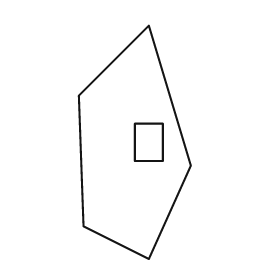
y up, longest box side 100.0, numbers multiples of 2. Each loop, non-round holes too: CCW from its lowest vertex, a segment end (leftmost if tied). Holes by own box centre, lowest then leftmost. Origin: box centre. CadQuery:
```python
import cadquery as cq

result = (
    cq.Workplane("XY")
    .moveTo(6.0, -50.0)
    .lineTo(24.0, -10.0)
    .lineTo(6.0, 50.0)
    .lineTo(-24.0, 20.0)
    .lineTo(-22.0, -36.0)
    .close()
    .moveTo(0.0, -8.0)
    .lineTo(12.0, -8.0)
    .lineTo(12.0, 8.0)
    .lineTo(0.0, 8.0)
    .close()
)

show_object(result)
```